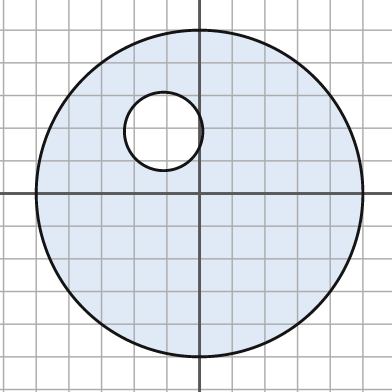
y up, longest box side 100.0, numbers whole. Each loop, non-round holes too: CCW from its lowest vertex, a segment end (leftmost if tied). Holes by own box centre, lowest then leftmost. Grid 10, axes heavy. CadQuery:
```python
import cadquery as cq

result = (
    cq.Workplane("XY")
    .moveTo(0.0, 0.0)
    .circle(50.0)
    .moveTo(-11.0, 19.0)
    .circle(12.0)
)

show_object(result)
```